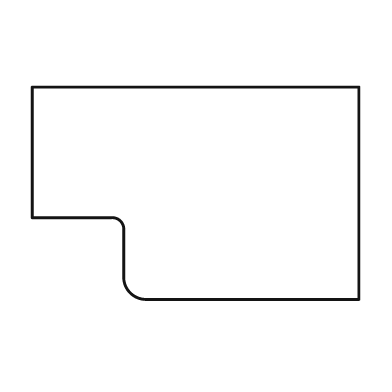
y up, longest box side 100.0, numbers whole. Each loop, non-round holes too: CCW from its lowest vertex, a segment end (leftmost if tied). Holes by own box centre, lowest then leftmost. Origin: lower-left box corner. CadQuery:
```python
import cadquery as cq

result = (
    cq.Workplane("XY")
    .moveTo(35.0, 0.0)
    .lineTo(100.0, 0.0)
    .lineTo(100.0, 65.0)
    .lineTo(0.0, 65.0)
    .lineTo(0.0, 25.0)
    .lineTo(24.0, 25.0)
    .threePointArc((27.0, 24.0), (28.0, 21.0))
    .lineTo(28.0, 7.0)
    .threePointArc((30.0, 2.0), (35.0, 0.0))
    .close()
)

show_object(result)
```